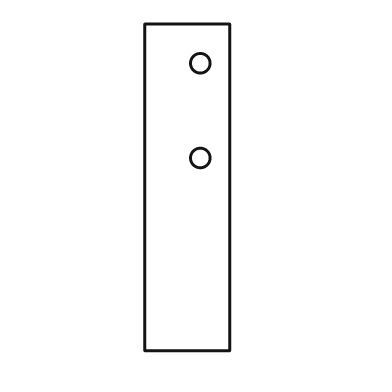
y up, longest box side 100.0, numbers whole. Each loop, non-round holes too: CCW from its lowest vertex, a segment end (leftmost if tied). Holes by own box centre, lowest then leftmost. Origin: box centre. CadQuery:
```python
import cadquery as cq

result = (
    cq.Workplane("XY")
    .moveTo(-13.0, -50.0)
    .lineTo(13.0, -50.0)
    .lineTo(13.0, 50.0)
    .lineTo(-13.0, 50.0)
    .close()
    .moveTo(4.0, 9.0)
    .circle(3.0)
    .moveTo(4.0, 38.0)
    .circle(3.0)
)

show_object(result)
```